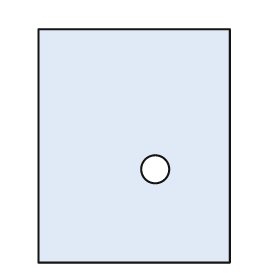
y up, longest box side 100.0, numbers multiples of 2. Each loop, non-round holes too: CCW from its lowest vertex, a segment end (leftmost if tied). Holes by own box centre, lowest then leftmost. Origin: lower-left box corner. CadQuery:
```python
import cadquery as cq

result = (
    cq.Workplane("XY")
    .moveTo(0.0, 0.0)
    .lineTo(82.0, 0.0)
    .lineTo(82.0, 100.0)
    .lineTo(0.0, 100.0)
    .close()
    .moveTo(50.0, 40.0)
    .circle(6.0)
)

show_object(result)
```